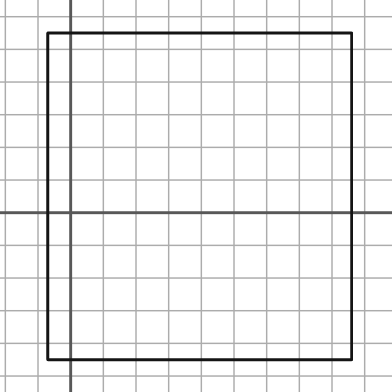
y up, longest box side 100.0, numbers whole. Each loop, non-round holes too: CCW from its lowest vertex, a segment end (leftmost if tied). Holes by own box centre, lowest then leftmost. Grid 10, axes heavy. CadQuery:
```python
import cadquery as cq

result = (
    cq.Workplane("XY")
    .moveTo(-7.0, -45.0)
    .lineTo(86.0, -45.0)
    .lineTo(86.0, 55.0)
    .lineTo(-7.0, 55.0)
    .close()
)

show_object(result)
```